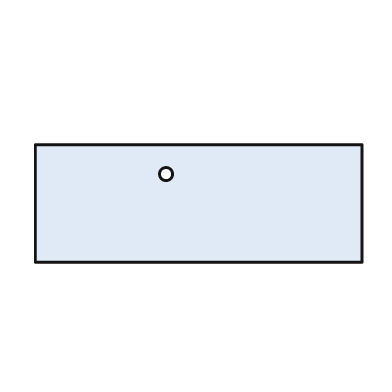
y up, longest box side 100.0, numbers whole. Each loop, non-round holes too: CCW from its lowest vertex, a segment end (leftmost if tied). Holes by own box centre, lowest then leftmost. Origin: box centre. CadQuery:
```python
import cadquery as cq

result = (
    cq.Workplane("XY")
    .moveTo(-50.0, -18.0)
    .lineTo(50.0, -18.0)
    .lineTo(50.0, 18.0)
    .lineTo(-50.0, 18.0)
    .close()
    .moveTo(-10.0, 9.0)
    .circle(2.0)
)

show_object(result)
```